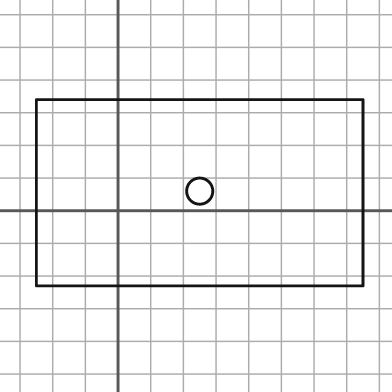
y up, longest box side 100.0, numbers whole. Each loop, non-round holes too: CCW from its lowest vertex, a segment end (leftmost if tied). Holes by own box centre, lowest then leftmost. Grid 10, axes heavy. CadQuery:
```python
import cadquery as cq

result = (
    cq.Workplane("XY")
    .moveTo(-25.0, -23.0)
    .lineTo(75.0, -23.0)
    .lineTo(75.0, 34.0)
    .lineTo(-25.0, 34.0)
    .close()
    .moveTo(25.0, 6.0)
    .circle(4.0)
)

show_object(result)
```